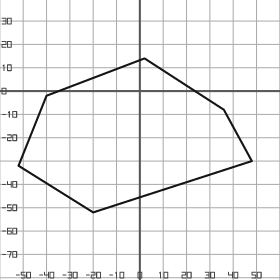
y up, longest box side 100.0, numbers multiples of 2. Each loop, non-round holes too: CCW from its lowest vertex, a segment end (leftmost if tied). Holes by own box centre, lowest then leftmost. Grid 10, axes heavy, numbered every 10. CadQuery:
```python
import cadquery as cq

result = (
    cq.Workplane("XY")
    .moveTo(-20.0, -52.0)
    .lineTo(48.0, -30.0)
    .lineTo(36.0, -8.0)
    .lineTo(2.0, 14.0)
    .lineTo(-40.0, -2.0)
    .lineTo(-52.0, -32.0)
    .close()
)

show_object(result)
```